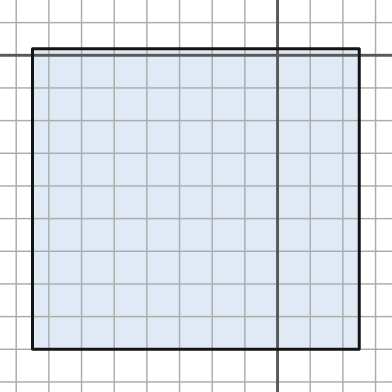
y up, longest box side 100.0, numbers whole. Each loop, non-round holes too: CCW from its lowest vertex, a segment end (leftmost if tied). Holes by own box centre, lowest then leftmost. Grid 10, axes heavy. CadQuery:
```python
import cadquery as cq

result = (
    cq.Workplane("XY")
    .moveTo(-75.0, -90.0)
    .lineTo(25.0, -90.0)
    .lineTo(25.0, 2.0)
    .lineTo(-75.0, 2.0)
    .close()
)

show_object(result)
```